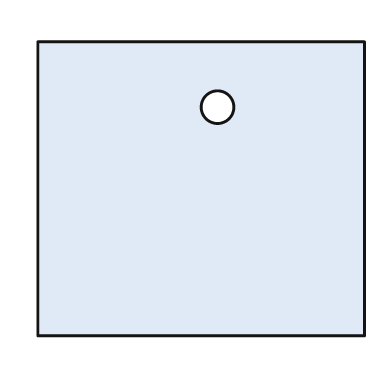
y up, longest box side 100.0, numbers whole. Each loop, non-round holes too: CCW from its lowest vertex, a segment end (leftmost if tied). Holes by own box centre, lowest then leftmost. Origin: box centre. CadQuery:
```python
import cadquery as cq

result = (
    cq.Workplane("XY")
    .moveTo(-50.0, -45.0)
    .lineTo(50.0, -45.0)
    .lineTo(50.0, 45.0)
    .lineTo(-50.0, 45.0)
    .close()
    .moveTo(5.0, 25.0)
    .circle(5.0)
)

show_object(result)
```